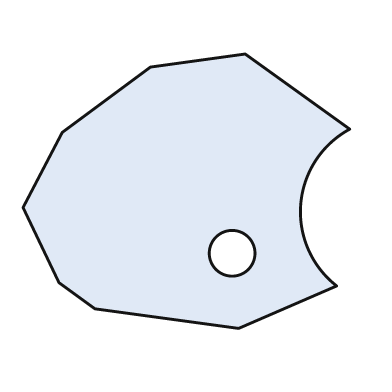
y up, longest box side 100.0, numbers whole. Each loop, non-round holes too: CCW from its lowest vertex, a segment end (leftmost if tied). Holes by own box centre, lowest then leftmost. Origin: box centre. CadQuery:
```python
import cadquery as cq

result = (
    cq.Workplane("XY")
    .moveTo(16.0, -42.0)
    .lineTo(46.0, -29.0)
    .threePointArc((35.0, -4.0), (50.0, 19.0))
    .lineTo(18.0, 42.0)
    .lineTo(-11.0, 38.0)
    .lineTo(-38.0, 18.0)
    .lineTo(-50.0, -5.0)
    .lineTo(-39.0, -28.0)
    .lineTo(-28.0, -36.0)
    .close()
    .moveTo(14.0, -19.0)
    .circle(7.0)
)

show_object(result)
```